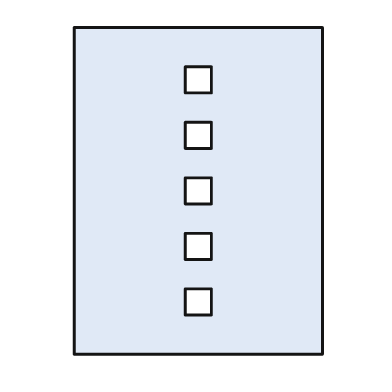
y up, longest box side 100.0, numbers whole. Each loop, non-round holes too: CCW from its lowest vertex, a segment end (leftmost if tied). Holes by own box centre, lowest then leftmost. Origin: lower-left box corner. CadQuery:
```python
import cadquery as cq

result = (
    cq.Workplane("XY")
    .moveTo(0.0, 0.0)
    .lineTo(76.0, 0.0)
    .lineTo(76.0, 100.0)
    .lineTo(0.0, 100.0)
    .close()
    .moveTo(34.0, 12.0)
    .lineTo(42.0, 12.0)
    .lineTo(42.0, 20.0)
    .lineTo(34.0, 20.0)
    .close()
    .moveTo(34.0, 29.0)
    .lineTo(42.0, 29.0)
    .lineTo(42.0, 37.0)
    .lineTo(34.0, 37.0)
    .close()
    .moveTo(34.0, 46.0)
    .lineTo(42.0, 46.0)
    .lineTo(42.0, 54.0)
    .lineTo(34.0, 54.0)
    .close()
    .moveTo(34.0, 63.0)
    .lineTo(42.0, 63.0)
    .lineTo(42.0, 71.0)
    .lineTo(34.0, 71.0)
    .close()
    .moveTo(34.0, 80.0)
    .lineTo(42.0, 80.0)
    .lineTo(42.0, 88.0)
    .lineTo(34.0, 88.0)
    .close()
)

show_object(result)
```